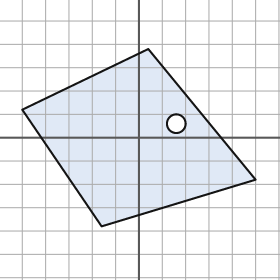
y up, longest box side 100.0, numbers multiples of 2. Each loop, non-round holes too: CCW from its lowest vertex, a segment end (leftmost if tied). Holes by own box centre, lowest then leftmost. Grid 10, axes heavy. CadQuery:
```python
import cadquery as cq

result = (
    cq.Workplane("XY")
    .moveTo(-16.0, -38.0)
    .lineTo(50.0, -18.0)
    .lineTo(4.0, 38.0)
    .lineTo(-50.0, 12.0)
    .close()
    .moveTo(16.0, 6.0)
    .circle(4.0)
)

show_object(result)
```